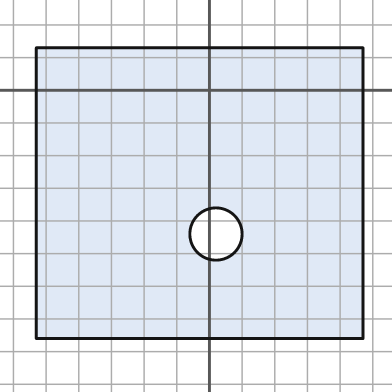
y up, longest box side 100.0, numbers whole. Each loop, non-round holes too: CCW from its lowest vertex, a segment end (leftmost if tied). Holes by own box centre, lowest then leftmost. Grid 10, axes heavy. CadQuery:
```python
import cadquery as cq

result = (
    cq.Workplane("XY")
    .moveTo(-53.0, -76.0)
    .lineTo(47.0, -76.0)
    .lineTo(47.0, 13.0)
    .lineTo(-53.0, 13.0)
    .close()
    .moveTo(2.0, -44.0)
    .circle(8.0)
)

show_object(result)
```